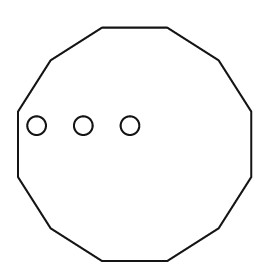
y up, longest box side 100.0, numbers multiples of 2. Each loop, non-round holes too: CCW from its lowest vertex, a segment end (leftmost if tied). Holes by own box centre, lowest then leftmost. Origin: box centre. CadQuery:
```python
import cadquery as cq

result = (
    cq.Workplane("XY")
    .moveTo(-14.0, -50.0)
    .lineTo(14.0, -50.0)
    .lineTo(36.0, -36.0)
    .lineTo(50.0, -14.0)
    .lineTo(50.0, 14.0)
    .lineTo(36.0, 36.0)
    .lineTo(14.0, 50.0)
    .lineTo(-14.0, 50.0)
    .lineTo(-36.0, 36.0)
    .lineTo(-50.0, 14.0)
    .lineTo(-50.0, -14.0)
    .lineTo(-36.0, -36.0)
    .close()
    .moveTo(-42.0, 8.0)
    .circle(4.0)
    .moveTo(-22.0, 8.0)
    .circle(4.0)
    .moveTo(-2.0, 8.0)
    .circle(4.0)
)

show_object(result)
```